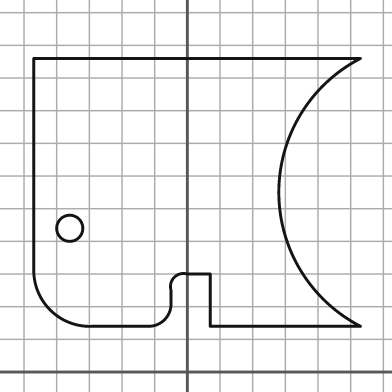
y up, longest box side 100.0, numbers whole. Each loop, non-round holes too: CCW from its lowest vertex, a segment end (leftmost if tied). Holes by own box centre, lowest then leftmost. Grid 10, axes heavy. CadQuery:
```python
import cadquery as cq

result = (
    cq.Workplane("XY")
    .moveTo(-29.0, 14.0)
    .lineTo(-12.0, 14.0)
    .threePointArc((-7.0, 16.0), (-5.0, 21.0))
    .lineTo(-5.0, 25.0)
    .threePointArc((-4.0, 29.0), (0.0, 30.0))
    .lineTo(7.0, 30.0)
    .lineTo(7.0, 14.0)
    .lineTo(53.0, 14.0)
    .threePointArc((28.0, 55.0), (53.0, 96.0))
    .lineTo(-47.0, 96.0)
    .lineTo(-47.0, 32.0)
    .threePointArc((-42.0, 19.0), (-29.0, 14.0))
    .close()
    .moveTo(-36.0, 44.0)
    .circle(4.0)
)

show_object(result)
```